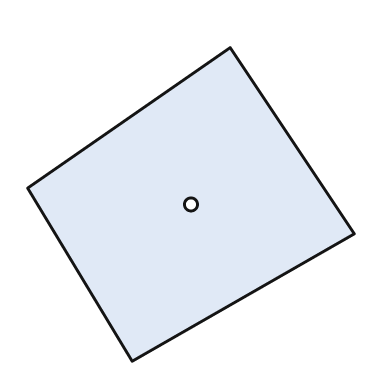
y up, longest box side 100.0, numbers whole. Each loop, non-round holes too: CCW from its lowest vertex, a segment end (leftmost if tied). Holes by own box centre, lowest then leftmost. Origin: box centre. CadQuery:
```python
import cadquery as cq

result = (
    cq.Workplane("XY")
    .moveTo(-18.0, -48.0)
    .lineTo(50.0, -9.0)
    .lineTo(12.0, 48.0)
    .lineTo(-50.0, 5.0)
    .close()
    .moveTo(0.0, 0.0)
    .circle(2.0)
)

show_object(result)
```